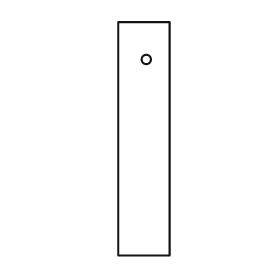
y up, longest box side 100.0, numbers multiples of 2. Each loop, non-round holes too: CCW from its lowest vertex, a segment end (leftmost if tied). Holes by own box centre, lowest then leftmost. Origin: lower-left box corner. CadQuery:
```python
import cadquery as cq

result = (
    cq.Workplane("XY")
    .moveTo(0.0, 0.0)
    .lineTo(22.0, 0.0)
    .lineTo(22.0, 100.0)
    .lineTo(0.0, 100.0)
    .close()
    .moveTo(12.0, 84.0)
    .circle(2.0)
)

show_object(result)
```